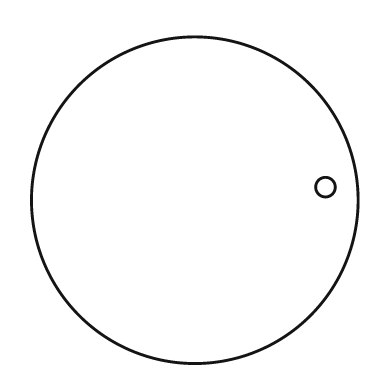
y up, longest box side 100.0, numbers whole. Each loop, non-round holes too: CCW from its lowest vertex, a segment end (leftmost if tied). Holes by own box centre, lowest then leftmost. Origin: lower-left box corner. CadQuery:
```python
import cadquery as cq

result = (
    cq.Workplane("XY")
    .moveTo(50.0, 50.0)
    .circle(50.0)
    .moveTo(90.0, 54.0)
    .circle(3.0)
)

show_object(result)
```